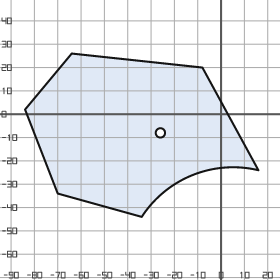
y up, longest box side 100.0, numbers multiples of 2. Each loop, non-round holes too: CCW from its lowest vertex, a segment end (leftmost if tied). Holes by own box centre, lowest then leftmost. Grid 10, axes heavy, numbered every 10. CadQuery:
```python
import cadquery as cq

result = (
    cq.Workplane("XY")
    .moveTo(-34.0, -44.0)
    .threePointArc((-12.0, -26.0), (16.0, -24.0))
    .lineTo(-8.0, 20.0)
    .lineTo(-64.0, 26.0)
    .lineTo(-84.0, 2.0)
    .lineTo(-70.0, -34.0)
    .close()
    .moveTo(-26.0, -8.0)
    .circle(2.0)
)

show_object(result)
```